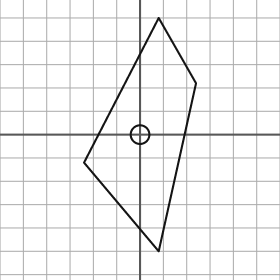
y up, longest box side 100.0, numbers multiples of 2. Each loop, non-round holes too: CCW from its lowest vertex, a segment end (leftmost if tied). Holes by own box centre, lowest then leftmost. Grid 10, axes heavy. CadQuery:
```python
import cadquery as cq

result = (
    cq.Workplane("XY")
    .moveTo(8.0, -50.0)
    .lineTo(24.0, 22.0)
    .lineTo(8.0, 50.0)
    .lineTo(-24.0, -12.0)
    .close()
    .moveTo(0.0, 0.0)
    .circle(4.0)
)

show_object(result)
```